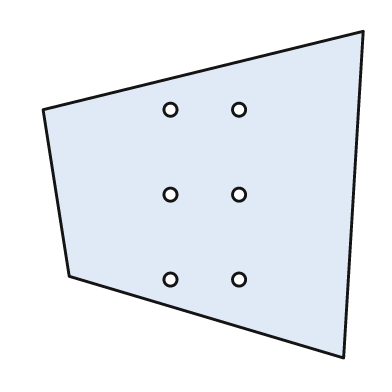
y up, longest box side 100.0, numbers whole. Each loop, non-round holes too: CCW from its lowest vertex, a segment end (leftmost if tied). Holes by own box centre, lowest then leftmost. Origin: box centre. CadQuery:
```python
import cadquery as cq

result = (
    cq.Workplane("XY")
    .moveTo(43.0, -50.0)
    .lineTo(49.0, 50.0)
    .lineTo(-49.0, 26.0)
    .lineTo(-41.0, -25.0)
    .close()
    .moveTo(-10.0, -26.0)
    .circle(2.0)
    .moveTo(11.0, -26.0)
    .circle(2.0)
    .moveTo(-10.0, 0.0)
    .circle(2.0)
    .moveTo(11.0, 0.0)
    .circle(2.0)
    .moveTo(-10.0, 26.0)
    .circle(2.0)
    .moveTo(11.0, 26.0)
    .circle(2.0)
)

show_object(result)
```